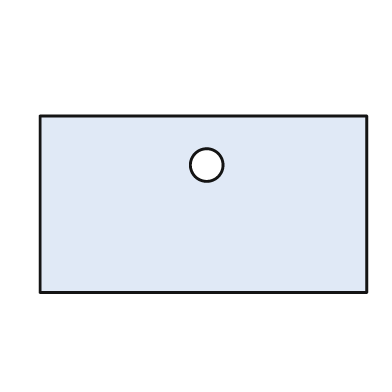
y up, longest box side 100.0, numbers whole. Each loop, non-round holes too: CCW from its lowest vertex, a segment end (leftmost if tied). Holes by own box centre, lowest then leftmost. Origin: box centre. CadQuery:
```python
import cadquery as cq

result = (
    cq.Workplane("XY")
    .moveTo(-50.0, -27.0)
    .lineTo(50.0, -27.0)
    .lineTo(50.0, 27.0)
    .lineTo(-50.0, 27.0)
    .close()
    .moveTo(1.0, 12.0)
    .circle(5.0)
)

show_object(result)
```